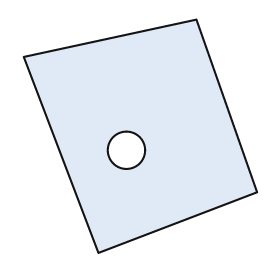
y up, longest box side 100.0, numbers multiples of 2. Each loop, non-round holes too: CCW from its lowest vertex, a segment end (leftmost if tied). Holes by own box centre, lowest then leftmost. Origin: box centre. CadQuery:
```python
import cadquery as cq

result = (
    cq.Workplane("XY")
    .moveTo(-18.0, -50.0)
    .lineTo(50.0, -24.0)
    .lineTo(24.0, 50.0)
    .lineTo(-50.0, 34.0)
    .close()
    .moveTo(-6.0, -6.0)
    .circle(8.0)
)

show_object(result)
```